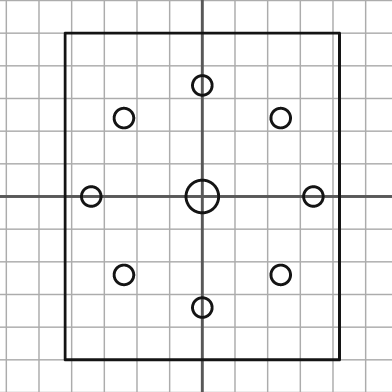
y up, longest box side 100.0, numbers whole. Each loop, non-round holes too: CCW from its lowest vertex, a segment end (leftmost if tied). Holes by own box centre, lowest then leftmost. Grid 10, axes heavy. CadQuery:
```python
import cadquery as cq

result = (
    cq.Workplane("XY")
    .moveTo(-42.0, -50.0)
    .lineTo(42.0, -50.0)
    .lineTo(42.0, 50.0)
    .lineTo(-42.0, 50.0)
    .close()
    .moveTo(0.0, -34.0)
    .circle(3.0)
    .moveTo(-24.0, -24.0)
    .circle(3.0)
    .moveTo(24.0, -24.0)
    .circle(3.0)
    .moveTo(-34.0, 0.0)
    .circle(3.0)
    .moveTo(0.0, 0.0)
    .circle(5.0)
    .moveTo(34.0, 0.0)
    .circle(3.0)
    .moveTo(-24.0, 24.0)
    .circle(3.0)
    .moveTo(24.0, 24.0)
    .circle(3.0)
    .moveTo(0.0, 34.0)
    .circle(3.0)
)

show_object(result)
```